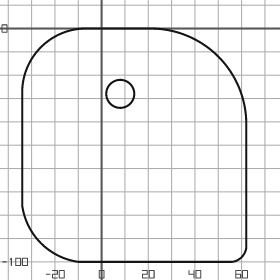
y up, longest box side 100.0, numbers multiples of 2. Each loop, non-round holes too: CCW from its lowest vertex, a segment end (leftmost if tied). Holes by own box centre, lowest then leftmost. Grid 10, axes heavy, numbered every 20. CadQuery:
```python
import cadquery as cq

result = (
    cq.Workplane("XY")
    .moveTo(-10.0, -100.0)
    .lineTo(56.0, -100.0)
    .threePointArc((60.0, -98.0), (62.0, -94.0))
    .lineTo(62.0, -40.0)
    .threePointArc((50.0, -12.0), (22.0, 0.0))
    .lineTo(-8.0, 0.0)
    .threePointArc((-26.0, -8.0), (-34.0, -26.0))
    .lineTo(-34.0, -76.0)
    .threePointArc((-26.0, -92.0), (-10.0, -100.0))
    .close()
    .moveTo(8.0, -28.0)
    .circle(6.0)
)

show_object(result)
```